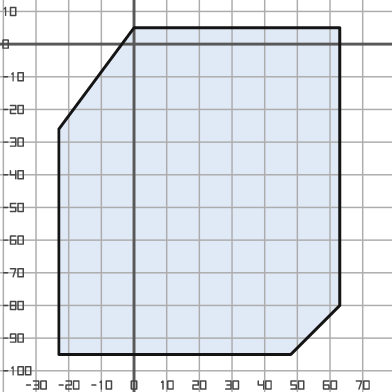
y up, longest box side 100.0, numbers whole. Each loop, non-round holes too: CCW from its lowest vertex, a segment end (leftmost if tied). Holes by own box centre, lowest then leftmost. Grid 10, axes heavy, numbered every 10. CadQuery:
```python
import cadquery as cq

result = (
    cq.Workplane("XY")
    .moveTo(-23.0, -95.0)
    .lineTo(48.0, -95.0)
    .lineTo(63.0, -80.0)
    .lineTo(63.0, 5.0)
    .lineTo(0.0, 5.0)
    .lineTo(-23.0, -26.0)
    .close()
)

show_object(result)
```